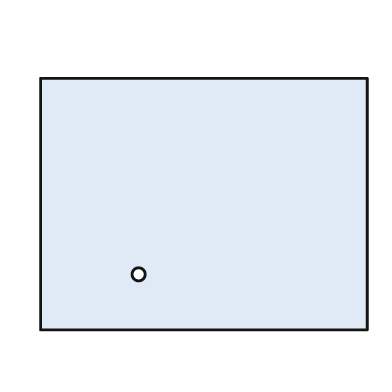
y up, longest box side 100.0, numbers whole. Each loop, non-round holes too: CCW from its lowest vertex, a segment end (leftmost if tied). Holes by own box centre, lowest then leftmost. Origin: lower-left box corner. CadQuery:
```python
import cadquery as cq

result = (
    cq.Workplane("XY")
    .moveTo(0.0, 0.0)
    .lineTo(100.0, 0.0)
    .lineTo(100.0, 77.0)
    .lineTo(0.0, 77.0)
    .close()
    .moveTo(30.0, 17.0)
    .circle(2.0)
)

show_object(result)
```